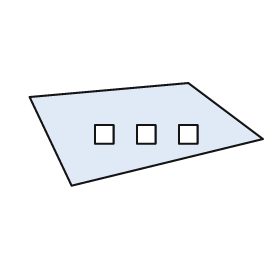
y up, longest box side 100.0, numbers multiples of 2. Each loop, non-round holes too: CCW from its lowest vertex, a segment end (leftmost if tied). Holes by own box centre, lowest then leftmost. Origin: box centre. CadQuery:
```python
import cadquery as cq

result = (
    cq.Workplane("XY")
    .moveTo(-32.0, -22.0)
    .lineTo(50.0, -2.0)
    .lineTo(18.0, 22.0)
    .lineTo(-50.0, 16.0)
    .close()
    .moveTo(-22.0, -4.0)
    .lineTo(-14.0, -4.0)
    .lineTo(-14.0, 4.0)
    .lineTo(-22.0, 4.0)
    .close()
    .moveTo(-4.0, -4.0)
    .lineTo(4.0, -4.0)
    .lineTo(4.0, 4.0)
    .lineTo(-4.0, 4.0)
    .close()
    .moveTo(14.0, -4.0)
    .lineTo(22.0, -4.0)
    .lineTo(22.0, 4.0)
    .lineTo(14.0, 4.0)
    .close()
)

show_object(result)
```